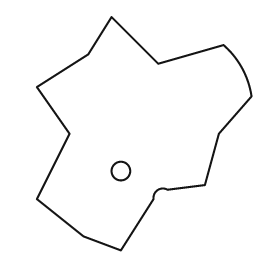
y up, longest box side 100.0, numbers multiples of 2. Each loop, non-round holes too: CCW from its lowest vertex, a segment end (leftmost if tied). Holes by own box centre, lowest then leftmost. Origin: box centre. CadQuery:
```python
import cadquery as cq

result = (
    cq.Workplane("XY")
    .moveTo(-10.0, -50.0)
    .lineTo(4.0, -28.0)
    .threePointArc((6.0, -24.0), (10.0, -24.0))
    .lineTo(26.0, -22.0)
    .lineTo(32.0, 0.0)
    .lineTo(46.0, 16.0)
    .threePointArc((42.0, 28.0), (34.0, 38.0))
    .lineTo(6.0, 30.0)
    .lineTo(-14.0, 50.0)
    .lineTo(-24.0, 34.0)
    .lineTo(-46.0, 20.0)
    .lineTo(-32.0, 0.0)
    .lineTo(-46.0, -28.0)
    .lineTo(-26.0, -44.0)
    .close()
    .moveTo(-10.0, -16.0)
    .circle(4.0)
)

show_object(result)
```